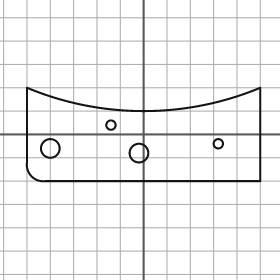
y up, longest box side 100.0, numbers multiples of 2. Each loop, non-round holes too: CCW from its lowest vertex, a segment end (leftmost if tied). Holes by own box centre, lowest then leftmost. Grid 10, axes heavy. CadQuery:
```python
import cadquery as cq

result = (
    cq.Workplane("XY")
    .moveTo(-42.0, -20.0)
    .lineTo(50.0, -20.0)
    .lineTo(50.0, 20.0)
    .threePointArc((0.0, 10.0), (-50.0, 20.0))
    .lineTo(-50.0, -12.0)
    .threePointArc((-48.0, -18.0), (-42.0, -20.0))
    .close()
    .moveTo(-2.0, -8.0)
    .circle(4.0)
    .moveTo(-40.0, -6.0)
    .circle(4.0)
    .moveTo(32.0, -4.0)
    .circle(2.0)
    .moveTo(-14.0, 4.0)
    .circle(2.0)
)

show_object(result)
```